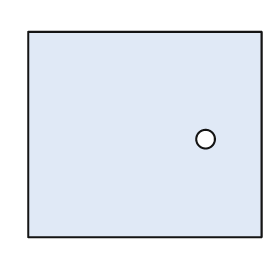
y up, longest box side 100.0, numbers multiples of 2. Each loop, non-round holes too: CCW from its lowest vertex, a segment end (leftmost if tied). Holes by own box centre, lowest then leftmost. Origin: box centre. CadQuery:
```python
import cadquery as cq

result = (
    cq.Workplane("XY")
    .moveTo(-50.0, -44.0)
    .lineTo(50.0, -44.0)
    .lineTo(50.0, 44.0)
    .lineTo(-50.0, 44.0)
    .close()
    .moveTo(26.0, -2.0)
    .circle(4.0)
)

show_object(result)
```